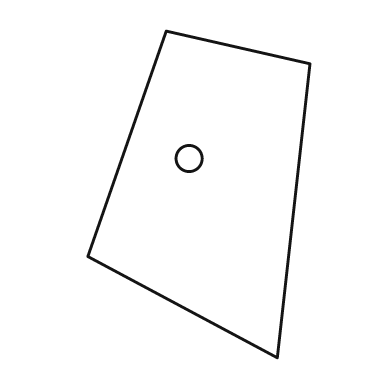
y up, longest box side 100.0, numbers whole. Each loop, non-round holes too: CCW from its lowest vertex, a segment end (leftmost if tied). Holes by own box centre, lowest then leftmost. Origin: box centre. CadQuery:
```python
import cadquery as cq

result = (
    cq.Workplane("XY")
    .moveTo(24.0, -50.0)
    .lineTo(34.0, 40.0)
    .lineTo(-10.0, 50.0)
    .lineTo(-34.0, -19.0)
    .close()
    .moveTo(-3.0, 11.0)
    .circle(4.0)
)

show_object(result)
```